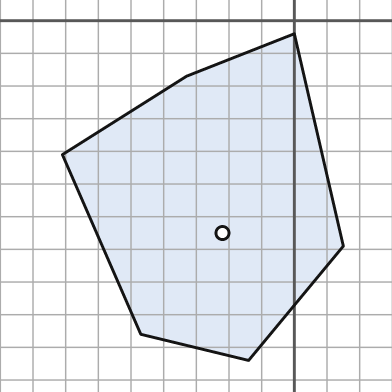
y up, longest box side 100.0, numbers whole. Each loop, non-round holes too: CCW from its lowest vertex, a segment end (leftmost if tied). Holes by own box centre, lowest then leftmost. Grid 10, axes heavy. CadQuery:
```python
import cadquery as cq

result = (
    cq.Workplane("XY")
    .moveTo(-14.0, -104.0)
    .lineTo(15.0, -69.0)
    .lineTo(0.0, -4.0)
    .lineTo(-33.0, -17.0)
    .lineTo(-71.0, -41.0)
    .lineTo(-47.0, -96.0)
    .close()
    .moveTo(-22.0, -65.0)
    .circle(2.0)
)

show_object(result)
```